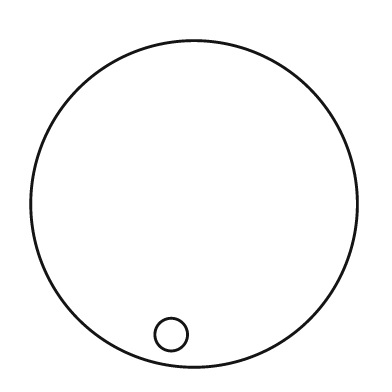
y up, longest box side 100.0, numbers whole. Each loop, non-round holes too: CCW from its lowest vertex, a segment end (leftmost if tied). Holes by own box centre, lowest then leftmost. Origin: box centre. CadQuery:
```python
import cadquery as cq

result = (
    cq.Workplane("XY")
    .moveTo(0.0, 0.0)
    .circle(50.0)
    .moveTo(-7.0, -40.0)
    .circle(5.0)
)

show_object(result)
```